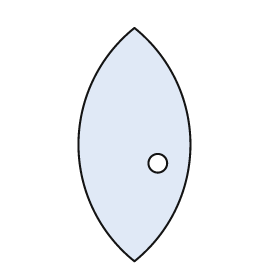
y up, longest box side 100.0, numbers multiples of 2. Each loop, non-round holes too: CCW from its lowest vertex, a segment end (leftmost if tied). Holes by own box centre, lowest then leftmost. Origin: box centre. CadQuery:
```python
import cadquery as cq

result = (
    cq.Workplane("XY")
    .moveTo(0.0, -50.0)
    .threePointArc((24.0, 0.0), (0.0, 50.0))
    .threePointArc((-24.0, 0.0), (0.0, -50.0))
    .close()
    .moveTo(10.0, -8.0)
    .circle(4.0)
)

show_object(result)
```